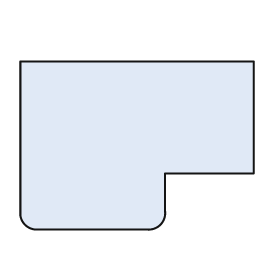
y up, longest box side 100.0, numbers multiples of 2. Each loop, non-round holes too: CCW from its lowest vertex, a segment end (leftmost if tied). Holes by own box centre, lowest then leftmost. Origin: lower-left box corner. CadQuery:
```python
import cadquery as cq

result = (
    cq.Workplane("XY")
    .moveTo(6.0, 0.0)
    .lineTo(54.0, 0.0)
    .threePointArc((60.0, 2.0), (62.0, 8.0))
    .lineTo(62.0, 24.0)
    .lineTo(100.0, 24.0)
    .lineTo(100.0, 72.0)
    .lineTo(0.0, 72.0)
    .lineTo(0.0, 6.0)
    .threePointArc((2.0, 2.0), (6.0, 0.0))
    .close()
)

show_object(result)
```